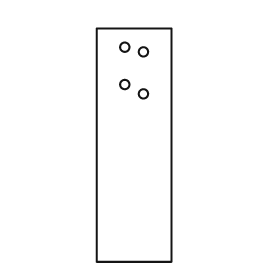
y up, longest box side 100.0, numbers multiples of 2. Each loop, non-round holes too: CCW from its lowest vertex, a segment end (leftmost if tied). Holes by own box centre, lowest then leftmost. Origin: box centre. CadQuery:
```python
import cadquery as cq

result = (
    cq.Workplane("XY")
    .moveTo(-16.0, -50.0)
    .lineTo(16.0, -50.0)
    .lineTo(16.0, 50.0)
    .lineTo(-16.0, 50.0)
    .close()
    .moveTo(4.0, 22.0)
    .circle(2.0)
    .moveTo(-4.0, 26.0)
    .circle(2.0)
    .moveTo(4.0, 40.0)
    .circle(2.0)
    .moveTo(-4.0, 42.0)
    .circle(2.0)
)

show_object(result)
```